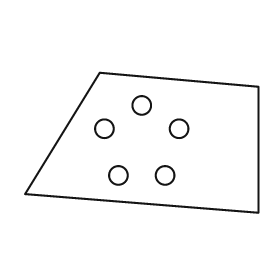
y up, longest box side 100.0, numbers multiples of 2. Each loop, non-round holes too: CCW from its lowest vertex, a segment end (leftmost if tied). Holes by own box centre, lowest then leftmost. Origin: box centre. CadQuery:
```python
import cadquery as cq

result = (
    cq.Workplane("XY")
    .moveTo(50.0, -30.0)
    .lineTo(50.0, 24.0)
    .lineTo(-18.0, 30.0)
    .lineTo(-50.0, -22.0)
    .close()
    .moveTo(-10.0, -14.0)
    .circle(4.0)
    .moveTo(10.0, -14.0)
    .circle(4.0)
    .moveTo(-16.0, 6.0)
    .circle(4.0)
    .moveTo(16.0, 6.0)
    .circle(4.0)
    .moveTo(0.0, 16.0)
    .circle(4.0)
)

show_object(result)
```